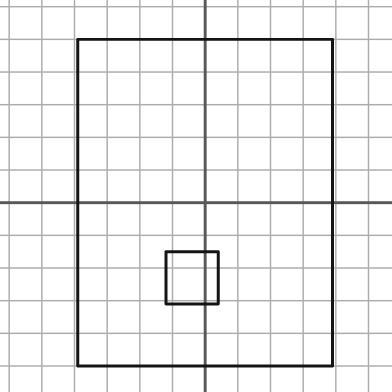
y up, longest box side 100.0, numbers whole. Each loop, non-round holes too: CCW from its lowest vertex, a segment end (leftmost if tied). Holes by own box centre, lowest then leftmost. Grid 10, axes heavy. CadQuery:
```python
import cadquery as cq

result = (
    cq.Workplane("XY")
    .moveTo(-39.0, -50.0)
    .lineTo(39.0, -50.0)
    .lineTo(39.0, 50.0)
    .lineTo(-39.0, 50.0)
    .close()
    .moveTo(-12.0, -31.0)
    .lineTo(4.0, -31.0)
    .lineTo(4.0, -15.0)
    .lineTo(-12.0, -15.0)
    .close()
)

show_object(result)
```